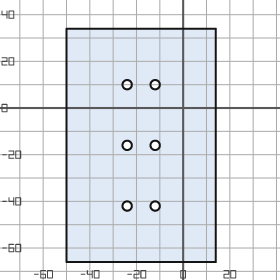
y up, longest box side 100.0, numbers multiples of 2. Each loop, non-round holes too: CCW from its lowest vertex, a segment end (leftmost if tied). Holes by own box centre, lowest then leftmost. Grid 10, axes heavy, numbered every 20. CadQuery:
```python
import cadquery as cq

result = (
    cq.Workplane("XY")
    .moveTo(-50.0, -66.0)
    .lineTo(14.0, -66.0)
    .lineTo(14.0, 34.0)
    .lineTo(-50.0, 34.0)
    .close()
    .moveTo(-24.0, -42.0)
    .circle(2.0)
    .moveTo(-12.0, -42.0)
    .circle(2.0)
    .moveTo(-24.0, -16.0)
    .circle(2.0)
    .moveTo(-12.0, -16.0)
    .circle(2.0)
    .moveTo(-24.0, 10.0)
    .circle(2.0)
    .moveTo(-12.0, 10.0)
    .circle(2.0)
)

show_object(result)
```